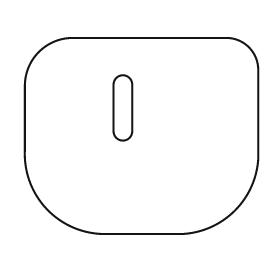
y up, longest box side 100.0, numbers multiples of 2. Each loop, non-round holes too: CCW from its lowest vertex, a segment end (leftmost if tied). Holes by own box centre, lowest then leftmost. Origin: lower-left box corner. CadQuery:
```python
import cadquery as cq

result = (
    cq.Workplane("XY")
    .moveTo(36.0, 0.0)
    .lineTo(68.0, 0.0)
    .threePointArc((90.0, 10.0), (100.0, 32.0))
    .lineTo(100.0, 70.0)
    .threePointArc((96.0, 80.0), (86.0, 84.0))
    .lineTo(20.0, 84.0)
    .threePointArc((6.0, 78.0), (0.0, 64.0))
    .lineTo(0.0, 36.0)
    .threePointArc((10.0, 10.0), (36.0, 0.0))
    .close()
    .moveTo(38.0, 44.0)
    .threePointArc((42.0, 40.0), (46.0, 44.0))
    .lineTo(46.0, 64.0)
    .threePointArc((42.0, 68.0), (38.0, 64.0))
    .close()
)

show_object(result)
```